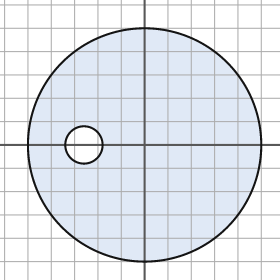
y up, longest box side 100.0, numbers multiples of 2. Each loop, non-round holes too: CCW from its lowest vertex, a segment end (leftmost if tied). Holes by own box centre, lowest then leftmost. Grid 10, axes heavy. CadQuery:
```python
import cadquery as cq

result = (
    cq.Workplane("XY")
    .moveTo(0.0, 0.0)
    .circle(50.0)
    .moveTo(-26.0, 0.0)
    .circle(8.0)
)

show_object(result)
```